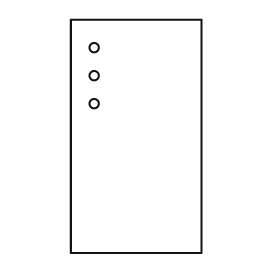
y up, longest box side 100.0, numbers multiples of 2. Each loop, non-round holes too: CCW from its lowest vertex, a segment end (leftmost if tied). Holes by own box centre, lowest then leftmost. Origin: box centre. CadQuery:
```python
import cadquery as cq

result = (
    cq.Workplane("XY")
    .moveTo(-28.0, -50.0)
    .lineTo(28.0, -50.0)
    .lineTo(28.0, 50.0)
    .lineTo(-28.0, 50.0)
    .close()
    .moveTo(-18.0, 14.0)
    .circle(2.0)
    .moveTo(-18.0, 26.0)
    .circle(2.0)
    .moveTo(-18.0, 38.0)
    .circle(2.0)
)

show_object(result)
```